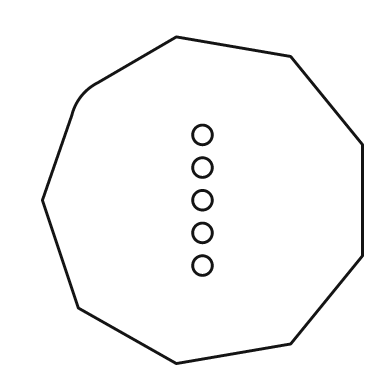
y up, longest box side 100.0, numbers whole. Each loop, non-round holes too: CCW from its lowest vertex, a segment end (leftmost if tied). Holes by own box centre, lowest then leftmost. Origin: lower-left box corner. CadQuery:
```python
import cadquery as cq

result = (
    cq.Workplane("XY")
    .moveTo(41.0, 0.0)
    .lineTo(76.0, 6.0)
    .lineTo(98.0, 33.0)
    .lineTo(98.0, 67.0)
    .lineTo(76.0, 94.0)
    .lineTo(41.0, 100.0)
    .lineTo(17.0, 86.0)
    .threePointArc((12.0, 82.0), (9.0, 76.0))
    .lineTo(0.0, 50.0)
    .lineTo(11.0, 17.0)
    .close()
    .moveTo(49.0, 30.0)
    .circle(3.0)
    .moveTo(49.0, 40.0)
    .circle(3.0)
    .moveTo(49.0, 50.0)
    .circle(3.0)
    .moveTo(49.0, 60.0)
    .circle(3.0)
    .moveTo(49.0, 70.0)
    .circle(3.0)
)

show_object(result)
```